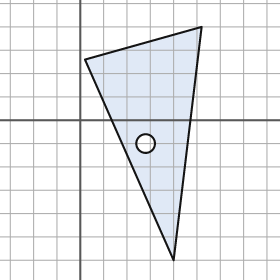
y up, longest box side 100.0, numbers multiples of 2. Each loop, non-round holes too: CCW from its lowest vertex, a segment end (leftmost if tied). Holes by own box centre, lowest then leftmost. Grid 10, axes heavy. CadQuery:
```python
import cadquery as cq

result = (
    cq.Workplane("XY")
    .moveTo(40.0, -60.0)
    .lineTo(52.0, 40.0)
    .lineTo(2.0, 26.0)
    .close()
    .moveTo(28.0, -10.0)
    .circle(4.0)
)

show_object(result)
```